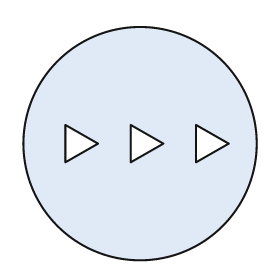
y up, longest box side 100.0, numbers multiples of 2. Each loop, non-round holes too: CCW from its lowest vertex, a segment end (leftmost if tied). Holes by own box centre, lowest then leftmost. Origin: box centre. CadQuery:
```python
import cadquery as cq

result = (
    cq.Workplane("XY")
    .moveTo(0.0, 0.0)
    .circle(50.0)
    .moveTo(-32.0, -8.0)
    .lineTo(-18.0, 0.0)
    .lineTo(-32.0, 8.0)
    .close()
    .moveTo(-4.0, -8.0)
    .lineTo(10.0, 0.0)
    .lineTo(-4.0, 8.0)
    .close()
    .moveTo(24.0, -8.0)
    .lineTo(38.0, 0.0)
    .lineTo(24.0, 8.0)
    .close()
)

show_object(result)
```